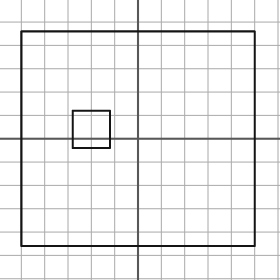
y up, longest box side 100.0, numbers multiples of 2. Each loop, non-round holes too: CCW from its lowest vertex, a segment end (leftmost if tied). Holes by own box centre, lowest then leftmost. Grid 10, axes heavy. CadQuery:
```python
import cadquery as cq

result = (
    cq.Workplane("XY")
    .moveTo(-50.0, -46.0)
    .lineTo(50.0, -46.0)
    .lineTo(50.0, 46.0)
    .lineTo(-50.0, 46.0)
    .close()
    .moveTo(-28.0, -4.0)
    .lineTo(-12.0, -4.0)
    .lineTo(-12.0, 12.0)
    .lineTo(-28.0, 12.0)
    .close()
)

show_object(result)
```